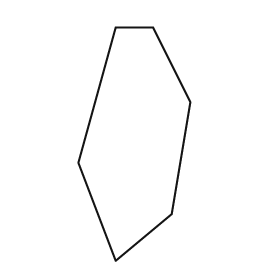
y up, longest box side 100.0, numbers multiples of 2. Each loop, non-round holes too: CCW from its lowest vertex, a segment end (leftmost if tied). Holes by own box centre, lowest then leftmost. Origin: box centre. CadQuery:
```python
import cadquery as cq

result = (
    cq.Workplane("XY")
    .moveTo(-8.0, -50.0)
    .lineTo(16.0, -30.0)
    .lineTo(24.0, 18.0)
    .lineTo(8.0, 50.0)
    .lineTo(-8.0, 50.0)
    .lineTo(-24.0, -8.0)
    .close()
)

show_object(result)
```